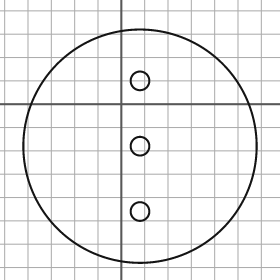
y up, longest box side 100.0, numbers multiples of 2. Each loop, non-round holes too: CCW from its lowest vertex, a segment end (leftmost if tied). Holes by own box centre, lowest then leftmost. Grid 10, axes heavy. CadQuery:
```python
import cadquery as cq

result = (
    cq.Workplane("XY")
    .moveTo(8.0, -18.0)
    .circle(50.0)
    .moveTo(8.0, -46.0)
    .circle(4.0)
    .moveTo(8.0, -18.0)
    .circle(4.0)
    .moveTo(8.0, 10.0)
    .circle(4.0)
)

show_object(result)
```